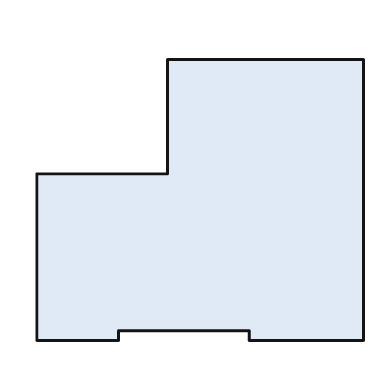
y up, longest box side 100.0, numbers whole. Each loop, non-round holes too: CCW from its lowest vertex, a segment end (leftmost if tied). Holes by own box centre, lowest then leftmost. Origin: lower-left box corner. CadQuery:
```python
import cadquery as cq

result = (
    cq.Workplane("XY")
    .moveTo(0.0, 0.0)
    .lineTo(25.0, 0.0)
    .lineTo(25.0, 3.0)
    .lineTo(65.0, 3.0)
    .lineTo(65.0, 0.0)
    .lineTo(100.0, 0.0)
    .lineTo(100.0, 86.0)
    .lineTo(40.0, 86.0)
    .lineTo(40.0, 51.0)
    .lineTo(0.0, 51.0)
    .close()
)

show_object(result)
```